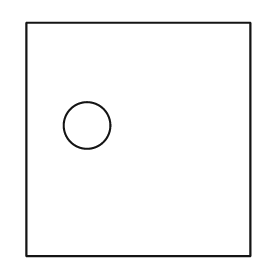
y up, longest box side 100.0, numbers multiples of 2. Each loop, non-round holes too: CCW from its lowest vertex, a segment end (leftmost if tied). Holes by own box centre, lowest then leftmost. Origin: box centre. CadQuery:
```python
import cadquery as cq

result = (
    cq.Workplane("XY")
    .moveTo(-48.0, -50.0)
    .lineTo(48.0, -50.0)
    .lineTo(48.0, 50.0)
    .lineTo(-48.0, 50.0)
    .close()
    .moveTo(-22.0, 6.0)
    .circle(10.0)
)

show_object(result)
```